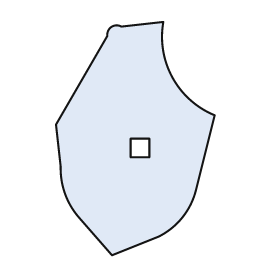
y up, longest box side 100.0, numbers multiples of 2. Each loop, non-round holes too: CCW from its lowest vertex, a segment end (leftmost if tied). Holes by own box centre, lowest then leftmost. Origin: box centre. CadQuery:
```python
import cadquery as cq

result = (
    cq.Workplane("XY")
    .moveTo(-10.0, -50.0)
    .lineTo(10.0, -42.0)
    .threePointArc((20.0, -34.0), (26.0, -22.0))
    .lineTo(34.0, 10.0)
    .threePointArc((16.0, 26.0), (12.0, 50.0))
    .lineTo(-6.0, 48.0)
    .threePointArc((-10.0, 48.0), (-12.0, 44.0))
    .lineTo(-34.0, 6.0)
    .lineTo(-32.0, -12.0)
    .threePointArc((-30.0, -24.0), (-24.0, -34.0))
    .close()
    .moveTo(-2.0, -8.0)
    .lineTo(6.0, -8.0)
    .lineTo(6.0, 0.0)
    .lineTo(-2.0, 0.0)
    .close()
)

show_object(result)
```